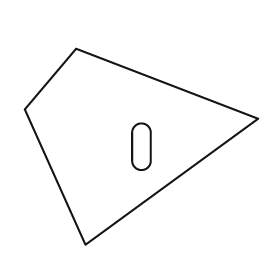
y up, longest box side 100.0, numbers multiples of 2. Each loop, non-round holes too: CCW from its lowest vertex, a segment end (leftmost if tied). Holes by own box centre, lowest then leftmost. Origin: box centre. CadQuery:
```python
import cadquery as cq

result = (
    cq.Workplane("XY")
    .moveTo(-24.0, -42.0)
    .lineTo(50.0, 12.0)
    .lineTo(-28.0, 42.0)
    .lineTo(-50.0, 16.0)
    .close()
    .moveTo(-4.0, -6.0)
    .threePointArc((0.0, -10.0), (4.0, -6.0))
    .lineTo(4.0, 6.0)
    .threePointArc((0.0, 10.0), (-4.0, 6.0))
    .close()
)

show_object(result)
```